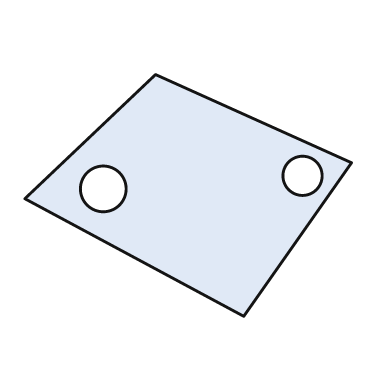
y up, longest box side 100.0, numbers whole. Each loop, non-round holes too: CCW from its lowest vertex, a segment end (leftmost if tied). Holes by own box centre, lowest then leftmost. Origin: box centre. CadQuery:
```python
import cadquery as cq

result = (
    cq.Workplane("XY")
    .moveTo(17.0, -37.0)
    .lineTo(50.0, 10.0)
    .lineTo(-10.0, 37.0)
    .lineTo(-50.0, -1.0)
    .close()
    .moveTo(-26.0, 2.0)
    .circle(7.0)
    .moveTo(35.0, 6.0)
    .circle(6.0)
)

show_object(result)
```